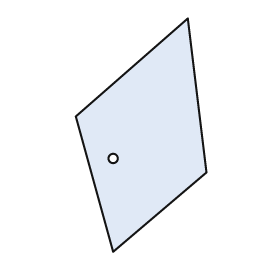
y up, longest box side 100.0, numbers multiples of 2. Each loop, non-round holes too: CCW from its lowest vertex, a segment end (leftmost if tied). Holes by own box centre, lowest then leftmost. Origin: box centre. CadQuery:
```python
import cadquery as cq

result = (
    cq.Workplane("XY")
    .moveTo(-12.0, -50.0)
    .lineTo(28.0, -16.0)
    .lineTo(20.0, 50.0)
    .lineTo(-28.0, 8.0)
    .close()
    .moveTo(-12.0, -10.0)
    .circle(2.0)
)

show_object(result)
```